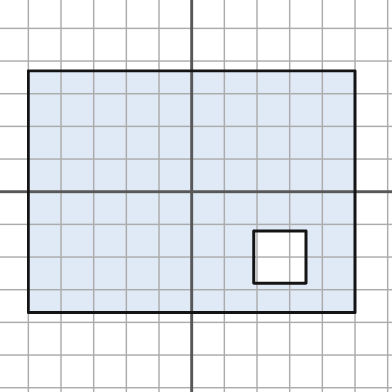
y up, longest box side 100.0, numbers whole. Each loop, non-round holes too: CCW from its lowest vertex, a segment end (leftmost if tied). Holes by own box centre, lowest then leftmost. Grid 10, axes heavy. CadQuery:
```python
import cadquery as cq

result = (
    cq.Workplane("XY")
    .moveTo(-50.0, -37.0)
    .lineTo(50.0, -37.0)
    .lineTo(50.0, 37.0)
    .lineTo(-50.0, 37.0)
    .close()
    .moveTo(19.0, -28.0)
    .lineTo(35.0, -28.0)
    .lineTo(35.0, -12.0)
    .lineTo(19.0, -12.0)
    .close()
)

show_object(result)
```